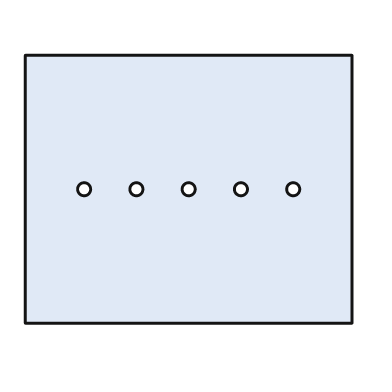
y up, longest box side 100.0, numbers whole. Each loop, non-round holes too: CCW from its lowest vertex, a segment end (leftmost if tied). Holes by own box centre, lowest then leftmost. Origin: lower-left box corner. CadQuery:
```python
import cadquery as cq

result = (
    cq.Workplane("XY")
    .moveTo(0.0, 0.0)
    .lineTo(100.0, 0.0)
    .lineTo(100.0, 82.0)
    .lineTo(0.0, 82.0)
    .close()
    .moveTo(18.0, 41.0)
    .circle(2.0)
    .moveTo(34.0, 41.0)
    .circle(2.0)
    .moveTo(50.0, 41.0)
    .circle(2.0)
    .moveTo(66.0, 41.0)
    .circle(2.0)
    .moveTo(82.0, 41.0)
    .circle(2.0)
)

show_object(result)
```